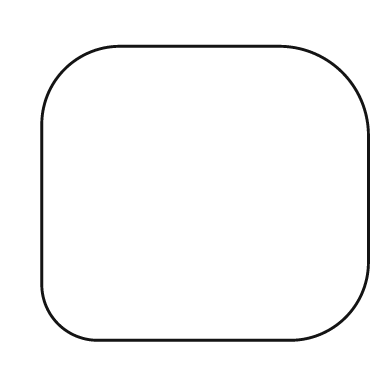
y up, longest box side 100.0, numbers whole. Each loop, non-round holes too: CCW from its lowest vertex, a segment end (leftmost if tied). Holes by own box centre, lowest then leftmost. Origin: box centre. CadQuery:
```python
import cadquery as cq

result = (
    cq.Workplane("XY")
    .moveTo(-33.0, -45.0)
    .lineTo(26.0, -45.0)
    .threePointArc((43.0, -38.0), (50.0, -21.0))
    .lineTo(50.0, 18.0)
    .threePointArc((42.0, 37.0), (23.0, 45.0))
    .lineTo(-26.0, 45.0)
    .threePointArc((-43.0, 38.0), (-50.0, 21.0))
    .lineTo(-50.0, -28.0)
    .threePointArc((-45.0, -40.0), (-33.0, -45.0))
    .close()
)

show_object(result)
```